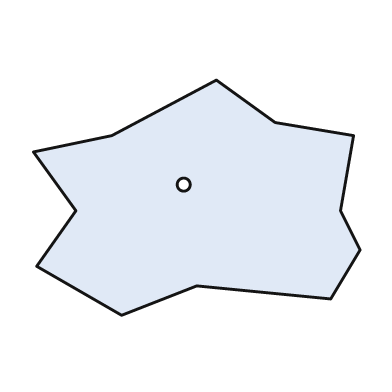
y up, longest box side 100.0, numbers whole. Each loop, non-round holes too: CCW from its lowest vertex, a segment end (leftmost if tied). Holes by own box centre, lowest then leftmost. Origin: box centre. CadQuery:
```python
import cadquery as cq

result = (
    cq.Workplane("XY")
    .moveTo(-23.0, -36.0)
    .lineTo(0.0, -27.0)
    .lineTo(41.0, -31.0)
    .lineTo(50.0, -16.0)
    .lineTo(44.0, -4.0)
    .lineTo(48.0, 19.0)
    .lineTo(24.0, 23.0)
    .lineTo(6.0, 36.0)
    .lineTo(-26.0, 19.0)
    .lineTo(-50.0, 14.0)
    .lineTo(-37.0, -4.0)
    .lineTo(-49.0, -21.0)
    .close()
    .moveTo(-4.0, 4.0)
    .circle(2.0)
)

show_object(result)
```